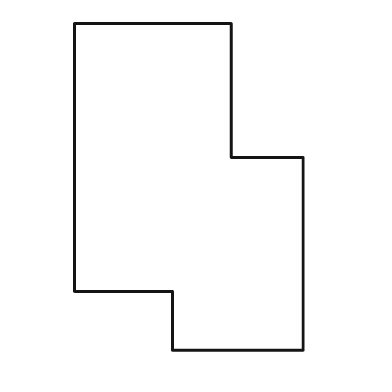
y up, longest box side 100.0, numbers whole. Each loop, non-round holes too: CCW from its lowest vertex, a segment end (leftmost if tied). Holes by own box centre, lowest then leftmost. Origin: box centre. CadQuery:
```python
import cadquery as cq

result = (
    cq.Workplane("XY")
    .moveTo(-5.0, -50.0)
    .lineTo(35.0, -50.0)
    .lineTo(35.0, 9.0)
    .lineTo(13.0, 9.0)
    .lineTo(13.0, 50.0)
    .lineTo(-35.0, 50.0)
    .lineTo(-35.0, -32.0)
    .lineTo(-5.0, -32.0)
    .close()
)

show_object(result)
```